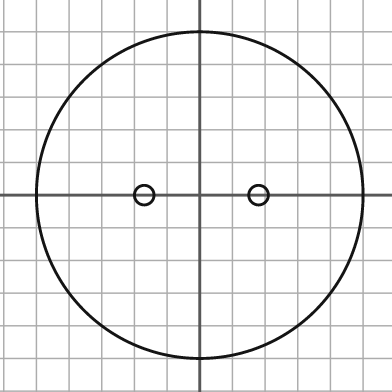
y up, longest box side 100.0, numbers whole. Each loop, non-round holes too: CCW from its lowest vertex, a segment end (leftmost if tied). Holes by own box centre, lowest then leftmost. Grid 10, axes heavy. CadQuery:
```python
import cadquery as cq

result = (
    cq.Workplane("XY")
    .moveTo(0.0, 0.0)
    .circle(50.0)
    .moveTo(-17.0, 0.0)
    .circle(3.0)
    .moveTo(18.0, 0.0)
    .circle(3.0)
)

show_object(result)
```